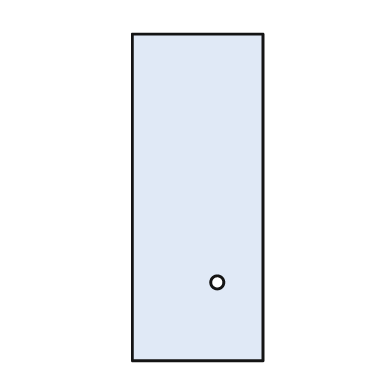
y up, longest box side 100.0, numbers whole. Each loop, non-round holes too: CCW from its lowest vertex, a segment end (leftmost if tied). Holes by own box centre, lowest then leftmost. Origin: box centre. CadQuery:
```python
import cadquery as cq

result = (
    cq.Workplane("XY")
    .moveTo(-20.0, -50.0)
    .lineTo(20.0, -50.0)
    .lineTo(20.0, 50.0)
    .lineTo(-20.0, 50.0)
    .close()
    .moveTo(6.0, -26.0)
    .circle(2.0)
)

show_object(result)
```